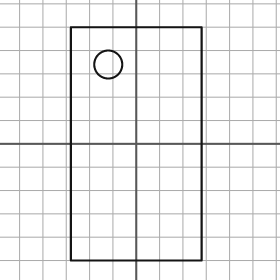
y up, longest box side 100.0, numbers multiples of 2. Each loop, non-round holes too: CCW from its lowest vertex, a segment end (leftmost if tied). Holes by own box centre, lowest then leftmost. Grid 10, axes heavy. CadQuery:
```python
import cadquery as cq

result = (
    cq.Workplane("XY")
    .moveTo(-28.0, -50.0)
    .lineTo(28.0, -50.0)
    .lineTo(28.0, 50.0)
    .lineTo(-28.0, 50.0)
    .close()
    .moveTo(-12.0, 34.0)
    .circle(6.0)
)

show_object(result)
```